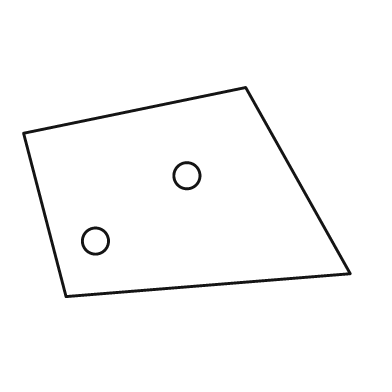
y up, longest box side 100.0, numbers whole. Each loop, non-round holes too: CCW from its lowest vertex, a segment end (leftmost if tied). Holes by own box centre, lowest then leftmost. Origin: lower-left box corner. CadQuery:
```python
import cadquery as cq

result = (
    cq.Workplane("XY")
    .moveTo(13.0, 0.0)
    .lineTo(100.0, 7.0)
    .lineTo(68.0, 64.0)
    .lineTo(0.0, 50.0)
    .close()
    .moveTo(22.0, 17.0)
    .circle(4.0)
    .moveTo(50.0, 37.0)
    .circle(4.0)
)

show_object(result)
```